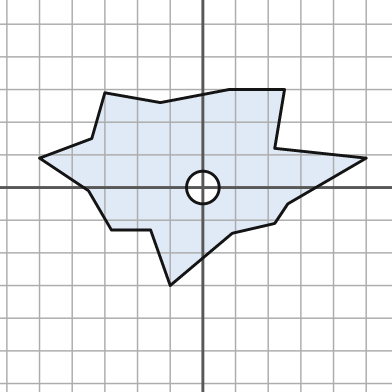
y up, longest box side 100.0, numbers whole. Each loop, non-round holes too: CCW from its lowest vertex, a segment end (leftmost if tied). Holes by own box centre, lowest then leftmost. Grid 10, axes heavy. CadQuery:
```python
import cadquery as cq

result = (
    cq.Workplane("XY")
    .moveTo(-10.0, -30.0)
    .lineTo(9.0, -14.0)
    .lineTo(22.0, -11.0)
    .lineTo(26.0, -5.0)
    .lineTo(50.0, 9.0)
    .lineTo(22.0, 12.0)
    .lineTo(25.0, 30.0)
    .lineTo(8.0, 30.0)
    .lineTo(-13.0, 26.0)
    .lineTo(-30.0, 29.0)
    .lineTo(-34.0, 15.0)
    .lineTo(-50.0, 9.0)
    .lineTo(-35.0, -1.0)
    .lineTo(-28.0, -13.0)
    .lineTo(-16.0, -13.0)
    .close()
    .moveTo(0.0, 0.0)
    .circle(5.0)
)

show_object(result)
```